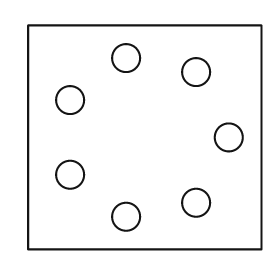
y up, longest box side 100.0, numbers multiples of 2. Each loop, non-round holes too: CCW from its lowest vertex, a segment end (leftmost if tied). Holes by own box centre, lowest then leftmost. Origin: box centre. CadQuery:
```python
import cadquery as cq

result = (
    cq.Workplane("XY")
    .moveTo(-50.0, -48.0)
    .lineTo(50.0, -48.0)
    .lineTo(50.0, 48.0)
    .lineTo(-50.0, 48.0)
    .close()
    .moveTo(-8.0, -34.0)
    .circle(6.0)
    .moveTo(22.0, -28.0)
    .circle(6.0)
    .moveTo(-32.0, -16.0)
    .circle(6.0)
    .moveTo(36.0, 0.0)
    .circle(6.0)
    .moveTo(-32.0, 16.0)
    .circle(6.0)
    .moveTo(22.0, 28.0)
    .circle(6.0)
    .moveTo(-8.0, 34.0)
    .circle(6.0)
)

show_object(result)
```